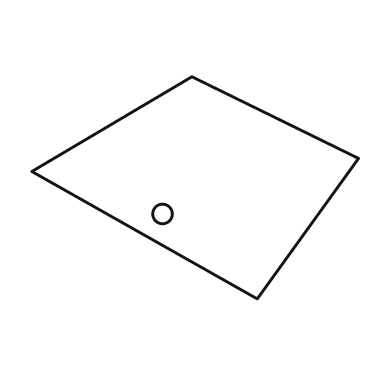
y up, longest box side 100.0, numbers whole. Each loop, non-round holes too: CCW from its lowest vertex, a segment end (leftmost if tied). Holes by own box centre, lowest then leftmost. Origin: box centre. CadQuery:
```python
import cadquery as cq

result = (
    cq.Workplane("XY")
    .moveTo(19.0, -34.0)
    .lineTo(50.0, 9.0)
    .lineTo(-1.0, 34.0)
    .lineTo(-50.0, 5.0)
    .close()
    .moveTo(-10.0, -8.0)
    .circle(3.0)
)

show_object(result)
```